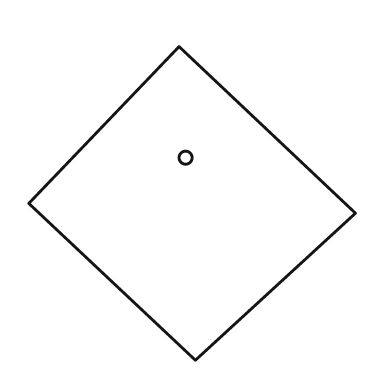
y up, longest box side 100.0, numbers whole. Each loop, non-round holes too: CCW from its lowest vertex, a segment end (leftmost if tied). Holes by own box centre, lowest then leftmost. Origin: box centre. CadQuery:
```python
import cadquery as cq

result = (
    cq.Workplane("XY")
    .moveTo(1.0, -48.0)
    .lineTo(50.0, -3.0)
    .lineTo(-4.0, 48.0)
    .lineTo(-50.0, 0.0)
    .close()
    .moveTo(-2.0, 14.0)
    .circle(2.0)
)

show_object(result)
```